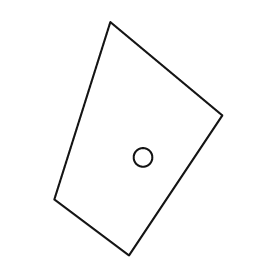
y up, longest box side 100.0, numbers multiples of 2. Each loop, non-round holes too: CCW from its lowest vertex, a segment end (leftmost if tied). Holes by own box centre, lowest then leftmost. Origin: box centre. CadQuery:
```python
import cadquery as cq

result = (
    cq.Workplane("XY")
    .moveTo(-4.0, -50.0)
    .lineTo(36.0, 10.0)
    .lineTo(-12.0, 50.0)
    .lineTo(-36.0, -26.0)
    .close()
    .moveTo(2.0, -8.0)
    .circle(4.0)
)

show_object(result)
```